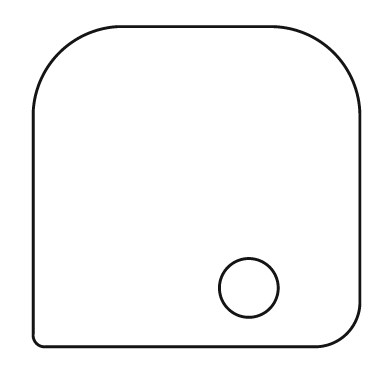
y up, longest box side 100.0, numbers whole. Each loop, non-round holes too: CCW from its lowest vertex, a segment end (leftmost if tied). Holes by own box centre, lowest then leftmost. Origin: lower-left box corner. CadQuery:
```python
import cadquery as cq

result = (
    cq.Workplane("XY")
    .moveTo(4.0, 0.0)
    .lineTo(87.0, 0.0)
    .threePointArc((96.0, 4.0), (100.0, 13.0))
    .lineTo(100.0, 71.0)
    .threePointArc((92.0, 90.0), (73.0, 98.0))
    .lineTo(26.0, 98.0)
    .threePointArc((8.0, 90.0), (0.0, 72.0))
    .lineTo(0.0, 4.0)
    .threePointArc((1.0, 1.0), (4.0, 0.0))
    .close()
    .moveTo(66.0, 18.0)
    .circle(9.0)
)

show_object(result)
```